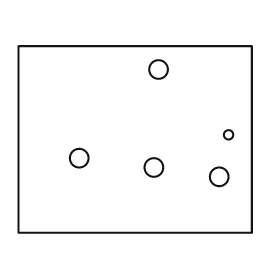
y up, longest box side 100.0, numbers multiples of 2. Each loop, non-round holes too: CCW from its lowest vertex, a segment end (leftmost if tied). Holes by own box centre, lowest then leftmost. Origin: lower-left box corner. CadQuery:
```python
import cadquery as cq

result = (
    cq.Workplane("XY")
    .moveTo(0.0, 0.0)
    .lineTo(100.0, 0.0)
    .lineTo(100.0, 80.0)
    .lineTo(0.0, 80.0)
    .close()
    .moveTo(86.0, 24.0)
    .circle(4.0)
    .moveTo(58.0, 28.0)
    .circle(4.0)
    .moveTo(26.0, 32.0)
    .circle(4.0)
    .moveTo(90.0, 42.0)
    .circle(2.0)
    .moveTo(60.0, 70.0)
    .circle(4.0)
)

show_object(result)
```